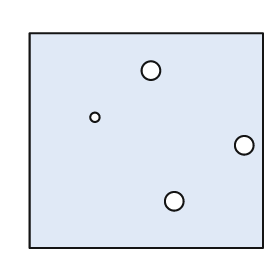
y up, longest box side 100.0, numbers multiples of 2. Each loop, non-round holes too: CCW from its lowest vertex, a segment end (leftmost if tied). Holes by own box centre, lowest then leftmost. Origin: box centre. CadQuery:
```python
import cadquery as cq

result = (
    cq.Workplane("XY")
    .moveTo(-50.0, -46.0)
    .lineTo(50.0, -46.0)
    .lineTo(50.0, 46.0)
    .lineTo(-50.0, 46.0)
    .close()
    .moveTo(12.0, -26.0)
    .circle(4.0)
    .moveTo(42.0, -2.0)
    .circle(4.0)
    .moveTo(-22.0, 10.0)
    .circle(2.0)
    .moveTo(2.0, 30.0)
    .circle(4.0)
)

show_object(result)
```